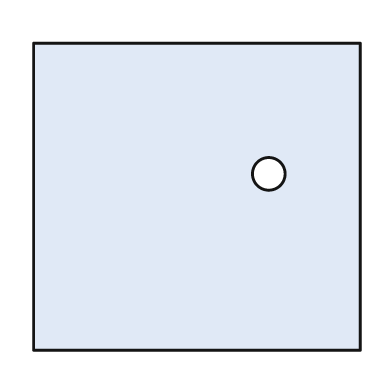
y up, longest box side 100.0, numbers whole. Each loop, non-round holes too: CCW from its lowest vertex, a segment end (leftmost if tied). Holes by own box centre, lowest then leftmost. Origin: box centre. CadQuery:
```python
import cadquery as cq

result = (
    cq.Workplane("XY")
    .moveTo(-50.0, -47.0)
    .lineTo(50.0, -47.0)
    .lineTo(50.0, 47.0)
    .lineTo(-50.0, 47.0)
    .close()
    .moveTo(22.0, 7.0)
    .circle(5.0)
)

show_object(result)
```